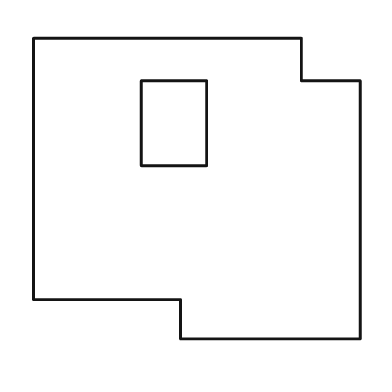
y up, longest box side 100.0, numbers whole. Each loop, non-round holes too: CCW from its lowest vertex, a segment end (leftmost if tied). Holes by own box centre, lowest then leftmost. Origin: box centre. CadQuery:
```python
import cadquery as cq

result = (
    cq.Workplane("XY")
    .moveTo(-5.0, -46.0)
    .lineTo(50.0, -46.0)
    .lineTo(50.0, 33.0)
    .lineTo(32.0, 33.0)
    .lineTo(32.0, 46.0)
    .lineTo(-50.0, 46.0)
    .lineTo(-50.0, -34.0)
    .lineTo(-5.0, -34.0)
    .close()
    .moveTo(-17.0, 7.0)
    .lineTo(3.0, 7.0)
    .lineTo(3.0, 33.0)
    .lineTo(-17.0, 33.0)
    .close()
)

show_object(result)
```